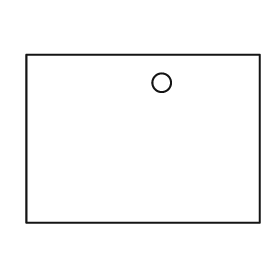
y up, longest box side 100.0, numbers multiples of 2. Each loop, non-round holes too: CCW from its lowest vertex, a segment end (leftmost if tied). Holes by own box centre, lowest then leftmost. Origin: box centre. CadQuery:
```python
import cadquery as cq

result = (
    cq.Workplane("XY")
    .moveTo(-50.0, -36.0)
    .lineTo(50.0, -36.0)
    .lineTo(50.0, 36.0)
    .lineTo(-50.0, 36.0)
    .close()
    .moveTo(8.0, 24.0)
    .circle(4.0)
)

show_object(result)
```